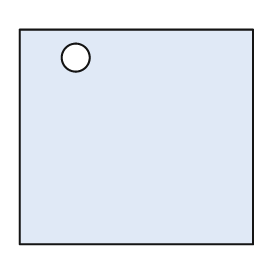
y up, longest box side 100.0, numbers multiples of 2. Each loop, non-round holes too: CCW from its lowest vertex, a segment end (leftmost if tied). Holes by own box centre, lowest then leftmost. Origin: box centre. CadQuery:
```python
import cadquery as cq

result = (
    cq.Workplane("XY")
    .moveTo(-50.0, -46.0)
    .lineTo(50.0, -46.0)
    .lineTo(50.0, 46.0)
    .lineTo(-50.0, 46.0)
    .close()
    .moveTo(-26.0, 34.0)
    .circle(6.0)
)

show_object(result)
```